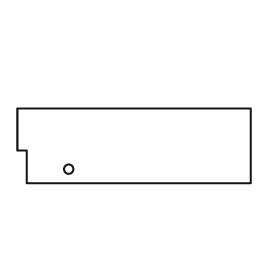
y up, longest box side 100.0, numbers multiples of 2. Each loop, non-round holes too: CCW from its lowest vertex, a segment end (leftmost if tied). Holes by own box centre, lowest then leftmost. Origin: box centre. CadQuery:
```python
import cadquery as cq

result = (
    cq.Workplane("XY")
    .moveTo(-46.0, -16.0)
    .lineTo(50.0, -16.0)
    .lineTo(50.0, 16.0)
    .lineTo(-50.0, 16.0)
    .lineTo(-50.0, -2.0)
    .lineTo(-46.0, -2.0)
    .close()
    .moveTo(-28.0, -10.0)
    .circle(2.0)
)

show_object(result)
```